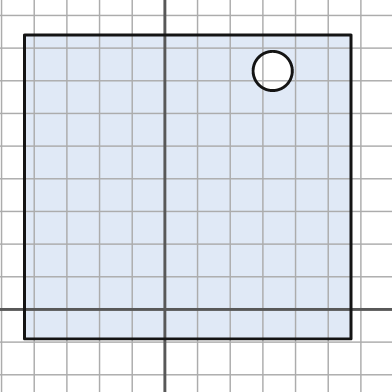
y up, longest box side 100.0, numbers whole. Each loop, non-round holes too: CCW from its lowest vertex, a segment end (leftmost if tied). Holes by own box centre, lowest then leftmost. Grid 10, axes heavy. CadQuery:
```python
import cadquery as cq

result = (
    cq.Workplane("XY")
    .moveTo(-43.0, -9.0)
    .lineTo(57.0, -9.0)
    .lineTo(57.0, 84.0)
    .lineTo(-43.0, 84.0)
    .close()
    .moveTo(33.0, 73.0)
    .circle(6.0)
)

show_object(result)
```